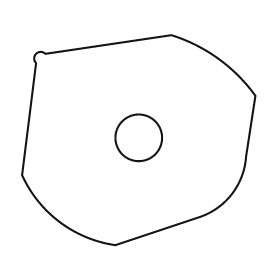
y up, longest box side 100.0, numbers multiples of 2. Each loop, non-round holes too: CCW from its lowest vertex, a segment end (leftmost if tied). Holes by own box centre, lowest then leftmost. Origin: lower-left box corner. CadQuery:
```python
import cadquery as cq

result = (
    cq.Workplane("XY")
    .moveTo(40.0, 0.0)
    .lineTo(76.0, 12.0)
    .threePointArc((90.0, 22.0), (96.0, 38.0))
    .lineTo(100.0, 64.0)
    .threePointArc((84.0, 80.0), (64.0, 90.0))
    .lineTo(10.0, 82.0)
    .threePointArc((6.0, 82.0), (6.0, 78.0))
    .lineTo(0.0, 30.0)
    .threePointArc((16.0, 10.0), (40.0, 0.0))
    .close()
    .moveTo(50.0, 46.0)
    .circle(10.0)
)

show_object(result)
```